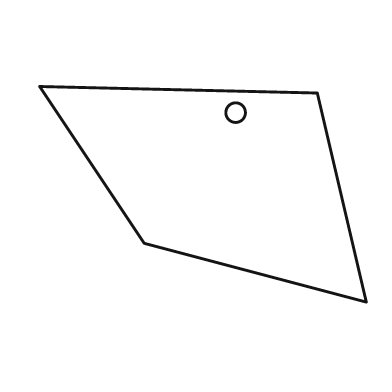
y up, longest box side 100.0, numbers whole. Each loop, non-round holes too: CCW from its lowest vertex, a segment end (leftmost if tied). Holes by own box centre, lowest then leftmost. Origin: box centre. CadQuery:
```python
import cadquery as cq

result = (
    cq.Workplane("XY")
    .moveTo(50.0, -33.0)
    .lineTo(35.0, 31.0)
    .lineTo(-50.0, 33.0)
    .lineTo(-18.0, -15.0)
    .close()
    .moveTo(10.0, 25.0)
    .circle(3.0)
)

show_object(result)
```